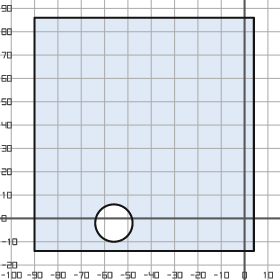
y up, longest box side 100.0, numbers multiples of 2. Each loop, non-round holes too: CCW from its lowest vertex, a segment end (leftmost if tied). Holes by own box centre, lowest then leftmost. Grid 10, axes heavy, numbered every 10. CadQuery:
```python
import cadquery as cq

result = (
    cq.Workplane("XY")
    .moveTo(-90.0, -14.0)
    .lineTo(4.0, -14.0)
    .lineTo(4.0, 86.0)
    .lineTo(-90.0, 86.0)
    .close()
    .moveTo(-56.0, -2.0)
    .circle(8.0)
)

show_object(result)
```